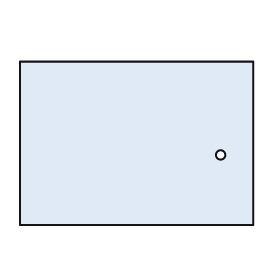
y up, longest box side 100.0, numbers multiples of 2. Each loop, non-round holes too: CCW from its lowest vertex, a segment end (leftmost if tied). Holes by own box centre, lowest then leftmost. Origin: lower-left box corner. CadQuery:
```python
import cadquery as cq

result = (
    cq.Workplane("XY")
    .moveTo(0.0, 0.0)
    .lineTo(100.0, 0.0)
    .lineTo(100.0, 70.0)
    .lineTo(0.0, 70.0)
    .close()
    .moveTo(86.0, 30.0)
    .circle(2.0)
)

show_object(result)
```